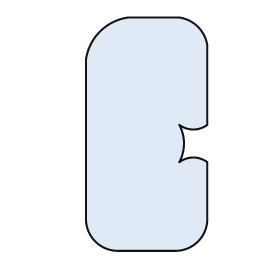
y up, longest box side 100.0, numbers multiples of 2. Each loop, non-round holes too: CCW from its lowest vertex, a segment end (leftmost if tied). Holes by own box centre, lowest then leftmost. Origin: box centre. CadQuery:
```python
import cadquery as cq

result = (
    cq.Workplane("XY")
    .moveTo(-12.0, -50.0)
    .lineTo(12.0, -50.0)
    .threePointArc((22.0, -46.0), (26.0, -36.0))
    .lineTo(26.0, -12.0)
    .threePointArc((20.0, -10.0), (14.0, -12.0))
    .threePointArc((16.0, -4.0), (14.0, 4.0))
    .threePointArc((20.0, 2.0), (26.0, 4.0))
    .lineTo(26.0, 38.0)
    .threePointArc((22.0, 46.0), (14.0, 50.0))
    .lineTo(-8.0, 50.0)
    .threePointArc((-20.0, 44.0), (-26.0, 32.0))
    .lineTo(-26.0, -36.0)
    .threePointArc((-22.0, -46.0), (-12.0, -50.0))
    .close()
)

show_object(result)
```